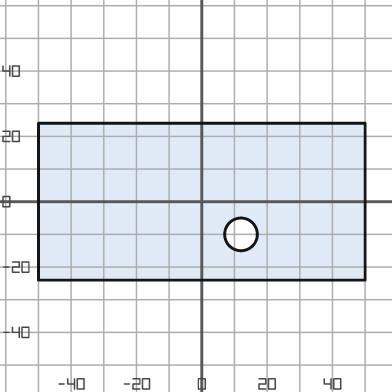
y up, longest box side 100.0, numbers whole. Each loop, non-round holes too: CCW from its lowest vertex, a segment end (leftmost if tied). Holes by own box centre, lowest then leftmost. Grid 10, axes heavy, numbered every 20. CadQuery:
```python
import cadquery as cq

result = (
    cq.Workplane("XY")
    .moveTo(-50.0, -24.0)
    .lineTo(50.0, -24.0)
    .lineTo(50.0, 24.0)
    .lineTo(-50.0, 24.0)
    .close()
    .moveTo(12.0, -10.0)
    .circle(5.0)
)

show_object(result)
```